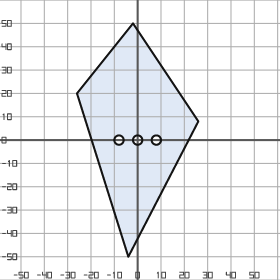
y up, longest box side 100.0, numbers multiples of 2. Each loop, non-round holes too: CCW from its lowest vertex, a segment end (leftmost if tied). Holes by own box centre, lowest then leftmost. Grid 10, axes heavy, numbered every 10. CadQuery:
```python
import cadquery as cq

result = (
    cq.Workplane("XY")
    .moveTo(-4.0, -50.0)
    .lineTo(26.0, 8.0)
    .lineTo(-2.0, 50.0)
    .lineTo(-26.0, 20.0)
    .close()
    .moveTo(-8.0, 0.0)
    .circle(2.0)
    .moveTo(0.0, 0.0)
    .circle(2.0)
    .moveTo(8.0, 0.0)
    .circle(2.0)
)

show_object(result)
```